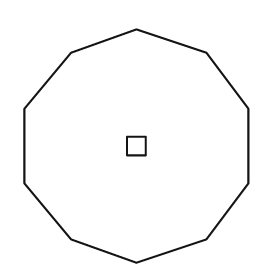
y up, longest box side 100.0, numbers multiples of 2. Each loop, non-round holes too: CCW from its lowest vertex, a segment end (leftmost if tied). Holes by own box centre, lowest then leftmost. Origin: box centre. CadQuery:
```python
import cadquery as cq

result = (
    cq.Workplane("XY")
    .moveTo(0.0, -50.0)
    .lineTo(30.0, -40.0)
    .lineTo(48.0, -16.0)
    .lineTo(48.0, 16.0)
    .lineTo(30.0, 40.0)
    .lineTo(0.0, 50.0)
    .lineTo(-28.0, 40.0)
    .lineTo(-48.0, 16.0)
    .lineTo(-48.0, -16.0)
    .lineTo(-28.0, -40.0)
    .close()
    .moveTo(-4.0, -4.0)
    .lineTo(4.0, -4.0)
    .lineTo(4.0, 4.0)
    .lineTo(-4.0, 4.0)
    .close()
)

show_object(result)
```